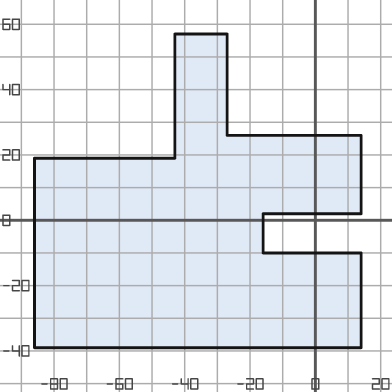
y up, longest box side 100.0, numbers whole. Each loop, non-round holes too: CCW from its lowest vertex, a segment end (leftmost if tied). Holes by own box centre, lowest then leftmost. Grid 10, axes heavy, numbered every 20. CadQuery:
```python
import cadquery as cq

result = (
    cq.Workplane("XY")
    .moveTo(-86.0, -39.0)
    .lineTo(14.0, -39.0)
    .lineTo(14.0, -10.0)
    .lineTo(-16.0, -10.0)
    .lineTo(-16.0, 2.0)
    .lineTo(14.0, 2.0)
    .lineTo(14.0, 26.0)
    .lineTo(-27.0, 26.0)
    .lineTo(-27.0, 57.0)
    .lineTo(-43.0, 57.0)
    .lineTo(-43.0, 19.0)
    .lineTo(-86.0, 19.0)
    .close()
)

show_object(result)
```